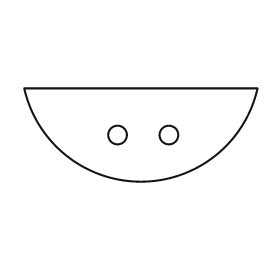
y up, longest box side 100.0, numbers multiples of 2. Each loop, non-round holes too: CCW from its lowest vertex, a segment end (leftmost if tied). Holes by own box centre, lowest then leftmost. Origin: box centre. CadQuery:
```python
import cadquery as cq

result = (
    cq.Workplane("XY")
    .moveTo(-50.0, 20.0)
    .threePointArc((0.0, -20.0), (50.0, 20.0))
    .close()
    .moveTo(-10.0, 0.0)
    .circle(4.0)
    .moveTo(12.0, 0.0)
    .circle(4.0)
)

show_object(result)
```